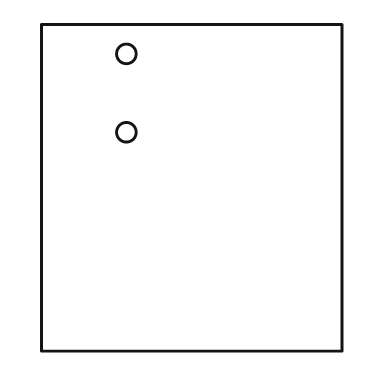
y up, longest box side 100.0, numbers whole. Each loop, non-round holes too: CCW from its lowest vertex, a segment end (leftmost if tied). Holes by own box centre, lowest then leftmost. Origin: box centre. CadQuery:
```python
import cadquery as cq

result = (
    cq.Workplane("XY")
    .moveTo(-46.0, -50.0)
    .lineTo(46.0, -50.0)
    .lineTo(46.0, 50.0)
    .lineTo(-46.0, 50.0)
    .close()
    .moveTo(-20.0, 17.0)
    .circle(3.0)
    .moveTo(-20.0, 41.0)
    .circle(3.0)
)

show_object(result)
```